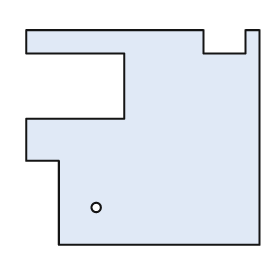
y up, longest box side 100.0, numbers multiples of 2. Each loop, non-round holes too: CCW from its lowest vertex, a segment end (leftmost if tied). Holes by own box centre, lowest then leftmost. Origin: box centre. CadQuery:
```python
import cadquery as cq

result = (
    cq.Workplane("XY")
    .moveTo(-36.0, -46.0)
    .lineTo(50.0, -46.0)
    .lineTo(50.0, 46.0)
    .lineTo(44.0, 46.0)
    .lineTo(44.0, 36.0)
    .lineTo(26.0, 36.0)
    .lineTo(26.0, 46.0)
    .lineTo(-50.0, 46.0)
    .lineTo(-50.0, 36.0)
    .lineTo(-8.0, 36.0)
    .lineTo(-8.0, 8.0)
    .lineTo(-50.0, 8.0)
    .lineTo(-50.0, -10.0)
    .lineTo(-36.0, -10.0)
    .close()
    .moveTo(-20.0, -30.0)
    .circle(2.0)
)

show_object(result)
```